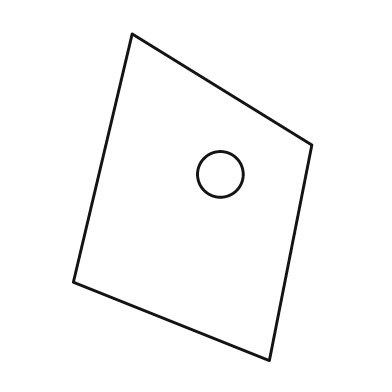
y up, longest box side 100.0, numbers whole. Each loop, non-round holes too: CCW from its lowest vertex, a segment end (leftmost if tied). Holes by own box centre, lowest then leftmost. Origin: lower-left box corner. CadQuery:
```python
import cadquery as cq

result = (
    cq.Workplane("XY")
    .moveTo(60.0, 0.0)
    .lineTo(73.0, 66.0)
    .lineTo(18.0, 100.0)
    .lineTo(0.0, 24.0)
    .close()
    .moveTo(45.0, 57.0)
    .circle(7.0)
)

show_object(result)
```